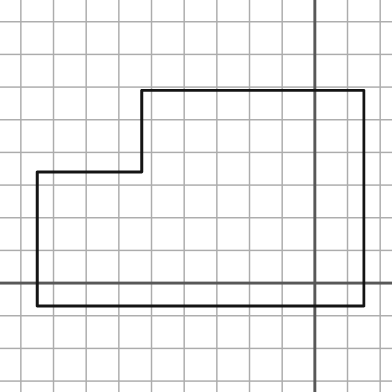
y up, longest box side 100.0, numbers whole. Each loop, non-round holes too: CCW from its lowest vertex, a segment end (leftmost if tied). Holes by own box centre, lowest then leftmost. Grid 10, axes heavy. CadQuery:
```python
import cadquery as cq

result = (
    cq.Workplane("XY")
    .moveTo(-85.0, -7.0)
    .lineTo(15.0, -7.0)
    .lineTo(15.0, 59.0)
    .lineTo(-53.0, 59.0)
    .lineTo(-53.0, 34.0)
    .lineTo(-85.0, 34.0)
    .close()
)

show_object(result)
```